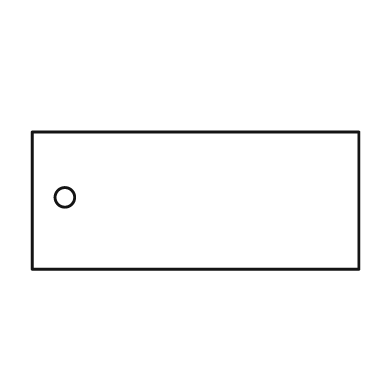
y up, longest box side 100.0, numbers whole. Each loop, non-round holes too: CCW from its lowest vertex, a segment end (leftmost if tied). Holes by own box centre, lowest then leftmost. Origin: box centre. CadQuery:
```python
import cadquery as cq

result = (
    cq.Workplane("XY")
    .moveTo(-50.0, -21.0)
    .lineTo(50.0, -21.0)
    .lineTo(50.0, 21.0)
    .lineTo(-50.0, 21.0)
    .close()
    .moveTo(-40.0, 1.0)
    .circle(3.0)
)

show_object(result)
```